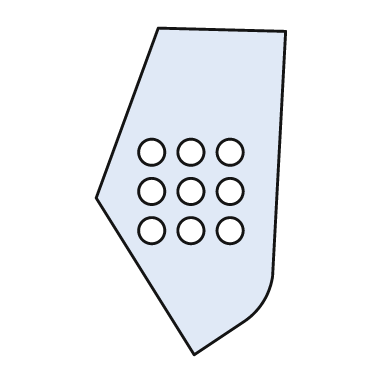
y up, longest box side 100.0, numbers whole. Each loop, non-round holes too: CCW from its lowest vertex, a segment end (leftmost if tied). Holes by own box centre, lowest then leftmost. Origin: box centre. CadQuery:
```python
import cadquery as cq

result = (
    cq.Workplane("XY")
    .moveTo(1.0, -50.0)
    .lineTo(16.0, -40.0)
    .threePointArc((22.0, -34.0), (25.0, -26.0))
    .lineTo(29.0, 49.0)
    .lineTo(-10.0, 50.0)
    .lineTo(-29.0, -2.0)
    .close()
    .moveTo(-12.0, -12.0)
    .circle(4.0)
    .moveTo(0.0, -12.0)
    .circle(4.0)
    .moveTo(12.0, -12.0)
    .circle(4.0)
    .moveTo(-12.0, 0.0)
    .circle(4.0)
    .moveTo(0.0, 0.0)
    .circle(4.0)
    .moveTo(12.0, 0.0)
    .circle(4.0)
    .moveTo(-12.0, 12.0)
    .circle(4.0)
    .moveTo(0.0, 12.0)
    .circle(4.0)
    .moveTo(12.0, 12.0)
    .circle(4.0)
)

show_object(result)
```